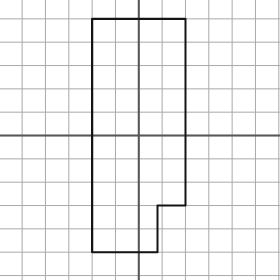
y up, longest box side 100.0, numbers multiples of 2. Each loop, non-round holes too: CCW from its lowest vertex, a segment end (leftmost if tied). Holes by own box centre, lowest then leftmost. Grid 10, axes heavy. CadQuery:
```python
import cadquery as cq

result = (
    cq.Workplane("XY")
    .moveTo(-20.0, -50.0)
    .lineTo(8.0, -50.0)
    .lineTo(8.0, -30.0)
    .lineTo(20.0, -30.0)
    .lineTo(20.0, 50.0)
    .lineTo(-20.0, 50.0)
    .close()
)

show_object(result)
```